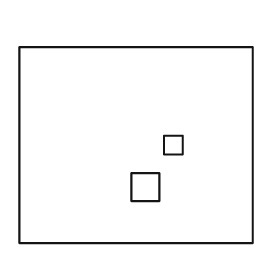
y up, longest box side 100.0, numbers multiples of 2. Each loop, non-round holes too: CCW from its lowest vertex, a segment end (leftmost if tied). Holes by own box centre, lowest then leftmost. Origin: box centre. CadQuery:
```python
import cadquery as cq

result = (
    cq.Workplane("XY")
    .moveTo(-50.0, -42.0)
    .lineTo(50.0, -42.0)
    .lineTo(50.0, 42.0)
    .lineTo(-50.0, 42.0)
    .close()
    .moveTo(-2.0, -24.0)
    .lineTo(10.0, -24.0)
    .lineTo(10.0, -12.0)
    .lineTo(-2.0, -12.0)
    .close()
    .moveTo(12.0, -4.0)
    .lineTo(20.0, -4.0)
    .lineTo(20.0, 4.0)
    .lineTo(12.0, 4.0)
    .close()
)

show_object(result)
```